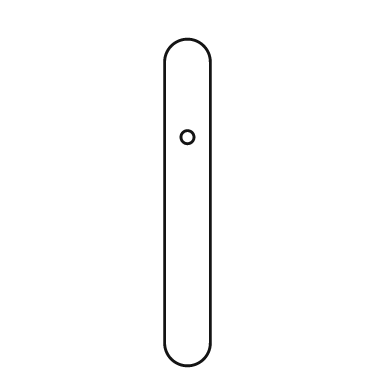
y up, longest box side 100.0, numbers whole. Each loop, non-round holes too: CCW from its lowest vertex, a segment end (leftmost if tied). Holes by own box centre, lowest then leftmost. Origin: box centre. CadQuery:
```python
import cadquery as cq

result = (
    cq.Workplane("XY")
    .moveTo(-7.0, -43.0)
    .threePointArc((0.0, -50.0), (7.0, -43.0))
    .lineTo(7.0, 43.0)
    .threePointArc((0.0, 50.0), (-7.0, 43.0))
    .close()
    .moveTo(0.0, 20.0)
    .circle(2.0)
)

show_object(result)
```